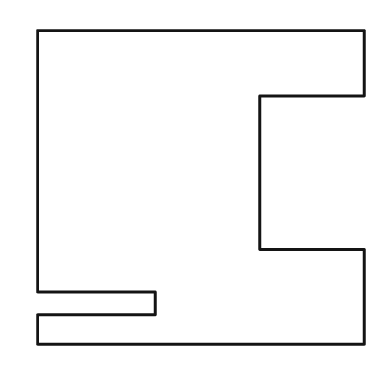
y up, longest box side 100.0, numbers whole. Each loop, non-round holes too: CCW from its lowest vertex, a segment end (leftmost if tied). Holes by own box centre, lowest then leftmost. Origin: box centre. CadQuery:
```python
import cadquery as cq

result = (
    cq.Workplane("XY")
    .moveTo(-50.0, -48.0)
    .lineTo(50.0, -48.0)
    .lineTo(50.0, -19.0)
    .lineTo(18.0, -19.0)
    .lineTo(18.0, 28.0)
    .lineTo(50.0, 28.0)
    .lineTo(50.0, 48.0)
    .lineTo(-50.0, 48.0)
    .lineTo(-50.0, -32.0)
    .lineTo(-14.0, -32.0)
    .lineTo(-14.0, -39.0)
    .lineTo(-50.0, -39.0)
    .close()
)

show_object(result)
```